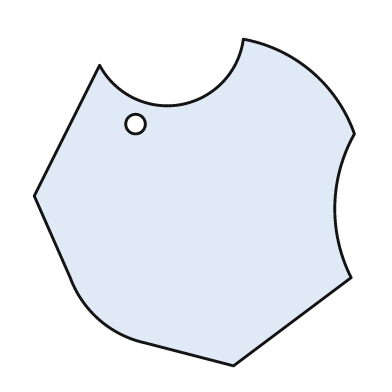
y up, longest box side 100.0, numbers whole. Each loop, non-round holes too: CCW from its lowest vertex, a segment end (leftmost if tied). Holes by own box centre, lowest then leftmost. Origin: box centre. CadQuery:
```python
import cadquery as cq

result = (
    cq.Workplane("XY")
    .moveTo(12.0, -50.0)
    .lineTo(48.0, -23.0)
    .threePointArc((43.0, -1.0), (49.0, 21.0))
    .threePointArc((36.0, 40.0), (15.0, 50.0))
    .threePointArc((-4.0, 30.0), (-29.0, 42.0))
    .lineTo(-49.0, 2.0)
    .lineTo(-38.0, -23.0)
    .threePointArc((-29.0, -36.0), (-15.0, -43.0))
    .close()
    .moveTo(-18.0, 24.0)
    .circle(3.0)
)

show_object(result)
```